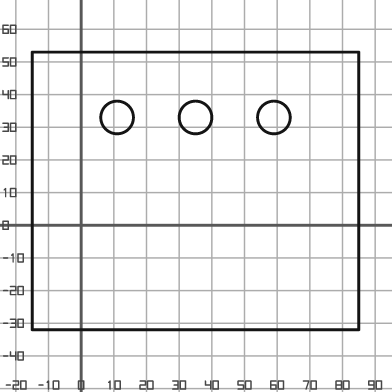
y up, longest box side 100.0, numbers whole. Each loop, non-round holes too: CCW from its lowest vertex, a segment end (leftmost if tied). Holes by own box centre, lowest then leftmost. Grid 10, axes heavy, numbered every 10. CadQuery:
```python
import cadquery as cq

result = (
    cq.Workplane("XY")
    .moveTo(-15.0, -32.0)
    .lineTo(85.0, -32.0)
    .lineTo(85.0, 53.0)
    .lineTo(-15.0, 53.0)
    .close()
    .moveTo(11.0, 33.0)
    .circle(5.0)
    .moveTo(35.0, 33.0)
    .circle(5.0)
    .moveTo(59.0, 33.0)
    .circle(5.0)
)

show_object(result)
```